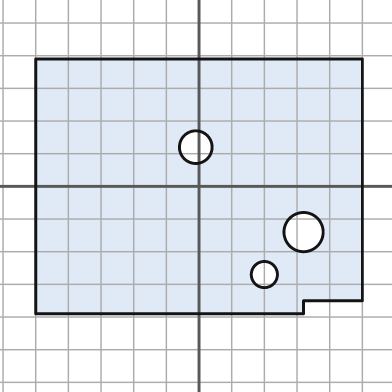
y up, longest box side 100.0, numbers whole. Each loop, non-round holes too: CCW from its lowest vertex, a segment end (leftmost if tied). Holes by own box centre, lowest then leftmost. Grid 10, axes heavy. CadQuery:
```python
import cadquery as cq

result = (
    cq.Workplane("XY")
    .moveTo(-50.0, -39.0)
    .lineTo(32.0, -39.0)
    .lineTo(32.0, -35.0)
    .lineTo(50.0, -35.0)
    .lineTo(50.0, 39.0)
    .lineTo(-50.0, 39.0)
    .close()
    .moveTo(20.0, -27.0)
    .circle(4.0)
    .moveTo(32.0, -14.0)
    .circle(6.0)
    .moveTo(-1.0, 12.0)
    .circle(5.0)
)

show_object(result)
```